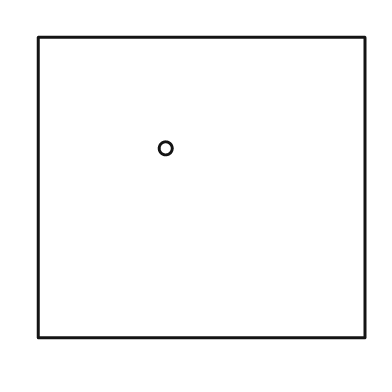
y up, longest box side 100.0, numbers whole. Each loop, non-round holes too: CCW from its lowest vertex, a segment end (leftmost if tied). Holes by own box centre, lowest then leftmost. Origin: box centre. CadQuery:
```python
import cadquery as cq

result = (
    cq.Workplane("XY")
    .moveTo(-50.0, -46.0)
    .lineTo(50.0, -46.0)
    .lineTo(50.0, 46.0)
    .lineTo(-50.0, 46.0)
    .close()
    .moveTo(-11.0, 12.0)
    .circle(2.0)
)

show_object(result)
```